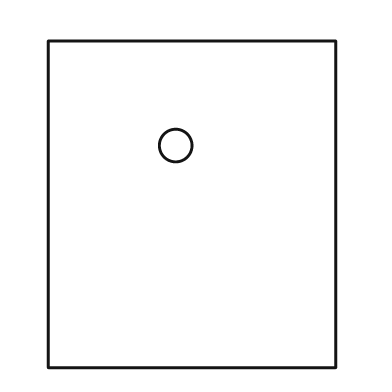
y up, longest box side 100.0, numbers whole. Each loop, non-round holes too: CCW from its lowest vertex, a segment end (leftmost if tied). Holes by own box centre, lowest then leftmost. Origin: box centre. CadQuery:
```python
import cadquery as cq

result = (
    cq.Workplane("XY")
    .moveTo(-44.0, -50.0)
    .lineTo(44.0, -50.0)
    .lineTo(44.0, 50.0)
    .lineTo(-44.0, 50.0)
    .close()
    .moveTo(-5.0, 18.0)
    .circle(5.0)
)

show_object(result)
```